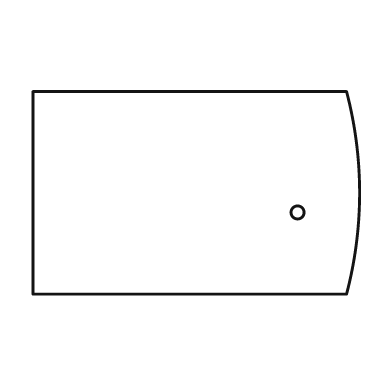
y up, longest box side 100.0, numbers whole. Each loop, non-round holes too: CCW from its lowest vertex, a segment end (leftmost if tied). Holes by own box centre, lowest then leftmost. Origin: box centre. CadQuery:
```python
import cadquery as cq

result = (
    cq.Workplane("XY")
    .moveTo(-50.0, -31.0)
    .lineTo(46.0, -31.0)
    .threePointArc((50.0, 0.0), (46.0, 31.0))
    .lineTo(-50.0, 31.0)
    .close()
    .moveTo(31.0, -6.0)
    .circle(2.0)
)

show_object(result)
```